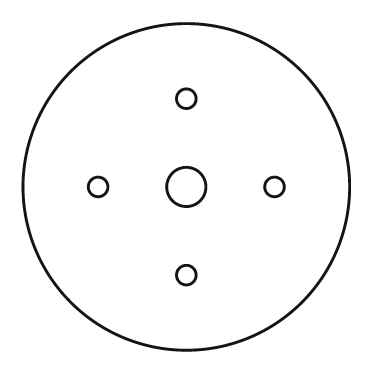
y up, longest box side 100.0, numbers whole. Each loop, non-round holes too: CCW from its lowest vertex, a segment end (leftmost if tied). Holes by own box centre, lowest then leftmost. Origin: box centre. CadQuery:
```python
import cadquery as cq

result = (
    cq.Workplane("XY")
    .moveTo(0.0, 0.0)
    .circle(50.0)
    .moveTo(0.0, -27.0)
    .circle(3.0)
    .moveTo(-27.0, 0.0)
    .circle(3.0)
    .moveTo(0.0, 0.0)
    .circle(6.0)
    .moveTo(27.0, 0.0)
    .circle(3.0)
    .moveTo(0.0, 27.0)
    .circle(3.0)
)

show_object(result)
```